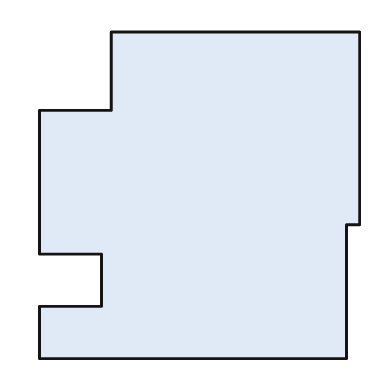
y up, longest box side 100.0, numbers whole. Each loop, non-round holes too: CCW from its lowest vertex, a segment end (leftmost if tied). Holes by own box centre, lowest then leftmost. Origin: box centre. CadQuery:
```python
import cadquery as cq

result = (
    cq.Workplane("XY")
    .moveTo(-49.0, -50.0)
    .lineTo(45.0, -50.0)
    .lineTo(45.0, -9.0)
    .lineTo(49.0, -9.0)
    .lineTo(49.0, 50.0)
    .lineTo(-27.0, 50.0)
    .lineTo(-27.0, 26.0)
    .lineTo(-49.0, 26.0)
    .lineTo(-49.0, -18.0)
    .lineTo(-30.0, -18.0)
    .lineTo(-30.0, -34.0)
    .lineTo(-49.0, -34.0)
    .close()
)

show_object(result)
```